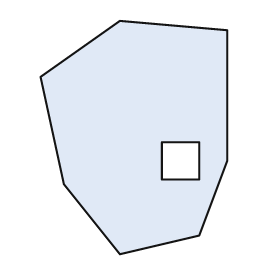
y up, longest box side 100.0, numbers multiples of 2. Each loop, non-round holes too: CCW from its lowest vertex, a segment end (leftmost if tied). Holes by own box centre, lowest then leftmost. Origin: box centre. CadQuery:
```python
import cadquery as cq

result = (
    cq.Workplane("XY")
    .moveTo(-6.0, -50.0)
    .lineTo(28.0, -42.0)
    .lineTo(40.0, -10.0)
    .lineTo(40.0, 46.0)
    .lineTo(-6.0, 50.0)
    .lineTo(-40.0, 26.0)
    .lineTo(-30.0, -20.0)
    .close()
    .moveTo(12.0, -18.0)
    .lineTo(28.0, -18.0)
    .lineTo(28.0, -2.0)
    .lineTo(12.0, -2.0)
    .close()
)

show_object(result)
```